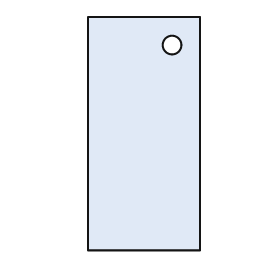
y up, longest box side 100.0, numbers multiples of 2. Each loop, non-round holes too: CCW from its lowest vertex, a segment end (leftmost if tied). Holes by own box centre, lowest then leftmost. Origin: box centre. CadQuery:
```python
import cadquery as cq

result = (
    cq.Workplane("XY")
    .moveTo(-24.0, -50.0)
    .lineTo(24.0, -50.0)
    .lineTo(24.0, 50.0)
    .lineTo(-24.0, 50.0)
    .close()
    .moveTo(12.0, 38.0)
    .circle(4.0)
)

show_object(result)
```